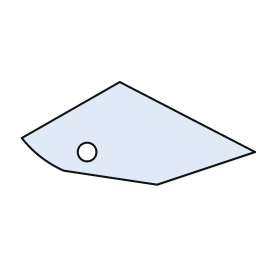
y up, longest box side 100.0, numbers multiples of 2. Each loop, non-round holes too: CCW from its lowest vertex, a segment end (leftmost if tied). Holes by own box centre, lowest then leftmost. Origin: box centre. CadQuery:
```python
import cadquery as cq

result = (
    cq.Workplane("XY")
    .moveTo(8.0, -22.0)
    .lineTo(50.0, -8.0)
    .lineTo(-8.0, 22.0)
    .lineTo(-50.0, -2.0)
    .threePointArc((-42.0, -10.0), (-32.0, -16.0))
    .close()
    .moveTo(-22.0, -8.0)
    .circle(4.0)
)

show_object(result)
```